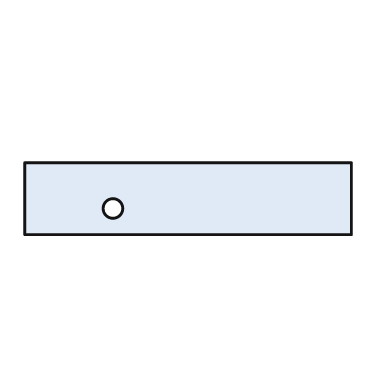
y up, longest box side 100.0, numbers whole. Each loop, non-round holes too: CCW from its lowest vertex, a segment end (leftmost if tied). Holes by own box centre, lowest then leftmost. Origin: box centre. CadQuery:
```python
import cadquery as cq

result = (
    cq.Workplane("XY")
    .moveTo(-50.0, -11.0)
    .lineTo(50.0, -11.0)
    .lineTo(50.0, 11.0)
    .lineTo(-50.0, 11.0)
    .close()
    .moveTo(-23.0, -3.0)
    .circle(3.0)
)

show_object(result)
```